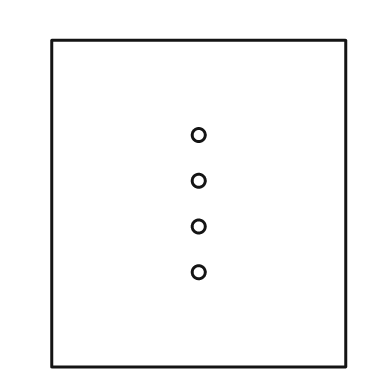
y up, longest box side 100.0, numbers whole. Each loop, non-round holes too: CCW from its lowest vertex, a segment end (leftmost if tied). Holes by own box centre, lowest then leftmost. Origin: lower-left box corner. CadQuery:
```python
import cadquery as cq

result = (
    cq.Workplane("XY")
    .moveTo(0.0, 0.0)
    .lineTo(90.0, 0.0)
    .lineTo(90.0, 100.0)
    .lineTo(0.0, 100.0)
    .close()
    .moveTo(45.0, 29.0)
    .circle(2.0)
    .moveTo(45.0, 43.0)
    .circle(2.0)
    .moveTo(45.0, 57.0)
    .circle(2.0)
    .moveTo(45.0, 71.0)
    .circle(2.0)
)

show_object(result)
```